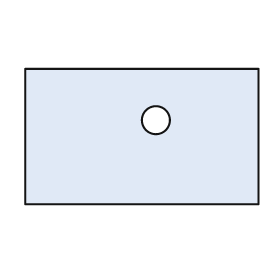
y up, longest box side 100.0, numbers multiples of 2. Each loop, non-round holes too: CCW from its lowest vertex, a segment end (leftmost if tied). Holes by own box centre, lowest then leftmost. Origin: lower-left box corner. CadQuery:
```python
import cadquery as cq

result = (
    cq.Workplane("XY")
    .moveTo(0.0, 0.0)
    .lineTo(100.0, 0.0)
    .lineTo(100.0, 58.0)
    .lineTo(0.0, 58.0)
    .close()
    .moveTo(56.0, 36.0)
    .circle(6.0)
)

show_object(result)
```